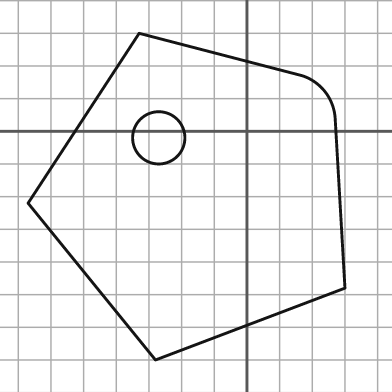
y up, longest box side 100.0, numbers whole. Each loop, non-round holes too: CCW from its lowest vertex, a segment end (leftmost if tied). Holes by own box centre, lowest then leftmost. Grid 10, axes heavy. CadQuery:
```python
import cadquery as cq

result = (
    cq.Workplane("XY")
    .moveTo(-28.0, -70.0)
    .lineTo(30.0, -48.0)
    .lineTo(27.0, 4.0)
    .threePointArc((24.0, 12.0), (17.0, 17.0))
    .lineTo(-33.0, 30.0)
    .lineTo(-67.0, -22.0)
    .close()
    .moveTo(-27.0, -2.0)
    .circle(8.0)
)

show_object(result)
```